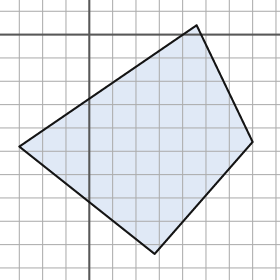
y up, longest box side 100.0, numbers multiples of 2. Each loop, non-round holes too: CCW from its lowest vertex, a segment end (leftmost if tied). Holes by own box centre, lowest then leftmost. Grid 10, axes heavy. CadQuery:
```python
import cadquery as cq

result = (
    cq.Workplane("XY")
    .moveTo(28.0, -94.0)
    .lineTo(70.0, -46.0)
    .lineTo(46.0, 4.0)
    .lineTo(-30.0, -48.0)
    .close()
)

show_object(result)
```